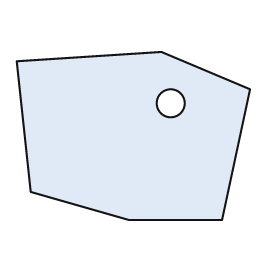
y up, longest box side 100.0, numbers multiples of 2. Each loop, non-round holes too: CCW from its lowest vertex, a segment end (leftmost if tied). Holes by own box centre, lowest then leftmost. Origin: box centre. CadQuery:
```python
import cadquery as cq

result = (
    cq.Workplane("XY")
    .moveTo(-2.0, -36.0)
    .lineTo(38.0, -36.0)
    .lineTo(50.0, 20.0)
    .lineTo(12.0, 36.0)
    .lineTo(-50.0, 32.0)
    .lineTo(-44.0, -24.0)
    .close()
    .moveTo(16.0, 14.0)
    .circle(6.0)
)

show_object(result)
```